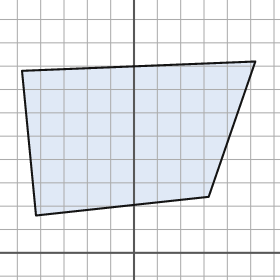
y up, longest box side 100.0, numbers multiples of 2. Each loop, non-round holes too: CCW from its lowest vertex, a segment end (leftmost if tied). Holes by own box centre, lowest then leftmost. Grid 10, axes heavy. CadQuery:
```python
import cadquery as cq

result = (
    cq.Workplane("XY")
    .moveTo(-42.0, 16.0)
    .lineTo(32.0, 24.0)
    .lineTo(52.0, 82.0)
    .lineTo(-48.0, 78.0)
    .close()
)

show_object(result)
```